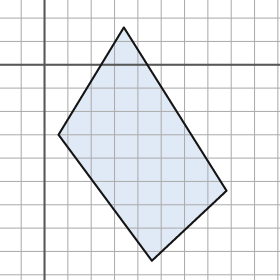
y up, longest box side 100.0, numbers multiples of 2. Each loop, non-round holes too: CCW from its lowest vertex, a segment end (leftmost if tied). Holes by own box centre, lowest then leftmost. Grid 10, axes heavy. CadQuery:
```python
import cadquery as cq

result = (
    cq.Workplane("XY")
    .moveTo(46.0, -84.0)
    .lineTo(78.0, -54.0)
    .lineTo(34.0, 16.0)
    .lineTo(6.0, -30.0)
    .close()
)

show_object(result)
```